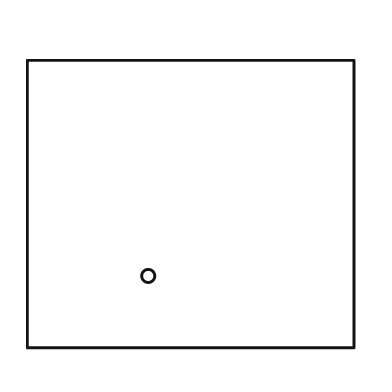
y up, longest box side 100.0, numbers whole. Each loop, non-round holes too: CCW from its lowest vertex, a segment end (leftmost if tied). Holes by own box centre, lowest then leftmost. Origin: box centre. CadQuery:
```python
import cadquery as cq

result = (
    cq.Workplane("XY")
    .moveTo(-50.0, -44.0)
    .lineTo(50.0, -44.0)
    .lineTo(50.0, 44.0)
    .lineTo(-50.0, 44.0)
    .close()
    .moveTo(-13.0, -22.0)
    .circle(2.0)
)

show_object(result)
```